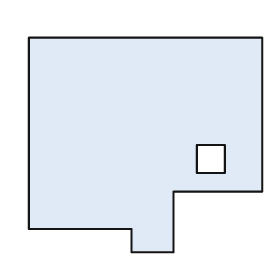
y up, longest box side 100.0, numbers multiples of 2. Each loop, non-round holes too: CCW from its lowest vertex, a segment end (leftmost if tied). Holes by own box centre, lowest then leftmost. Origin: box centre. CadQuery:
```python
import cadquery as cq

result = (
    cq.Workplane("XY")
    .moveTo(-6.0, -46.0)
    .lineTo(12.0, -46.0)
    .lineTo(12.0, -20.0)
    .lineTo(50.0, -20.0)
    .lineTo(50.0, 46.0)
    .lineTo(-50.0, 46.0)
    .lineTo(-50.0, -36.0)
    .lineTo(-6.0, -36.0)
    .close()
    .moveTo(22.0, -12.0)
    .lineTo(34.0, -12.0)
    .lineTo(34.0, 0.0)
    .lineTo(22.0, 0.0)
    .close()
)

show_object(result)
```